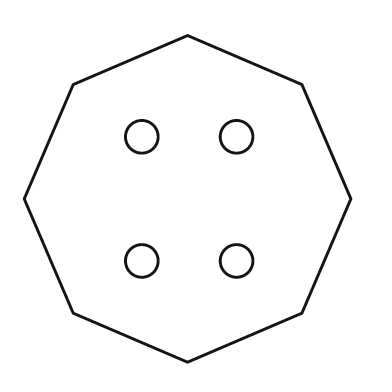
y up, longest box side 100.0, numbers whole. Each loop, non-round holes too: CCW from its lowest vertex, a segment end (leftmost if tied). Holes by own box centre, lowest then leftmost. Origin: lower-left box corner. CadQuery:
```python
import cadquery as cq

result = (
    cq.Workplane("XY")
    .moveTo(50.0, 0.0)
    .lineTo(85.0, 15.0)
    .lineTo(100.0, 50.0)
    .lineTo(85.0, 85.0)
    .lineTo(50.0, 100.0)
    .lineTo(15.0, 85.0)
    .lineTo(0.0, 50.0)
    .lineTo(15.0, 15.0)
    .close()
    .moveTo(36.0, 31.0)
    .circle(5.0)
    .moveTo(65.0, 31.0)
    .circle(5.0)
    .moveTo(36.0, 69.0)
    .circle(5.0)
    .moveTo(65.0, 69.0)
    .circle(5.0)
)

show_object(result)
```